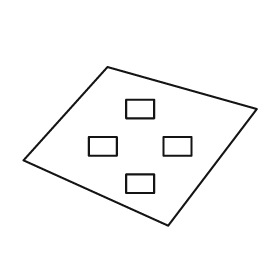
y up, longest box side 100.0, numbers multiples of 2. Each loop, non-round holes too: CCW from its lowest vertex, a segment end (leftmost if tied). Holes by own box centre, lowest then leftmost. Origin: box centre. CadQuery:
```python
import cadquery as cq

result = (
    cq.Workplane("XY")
    .moveTo(12.0, -34.0)
    .lineTo(50.0, 16.0)
    .lineTo(-14.0, 34.0)
    .lineTo(-50.0, -6.0)
    .close()
    .moveTo(-6.0, -20.0)
    .lineTo(6.0, -20.0)
    .lineTo(6.0, -12.0)
    .lineTo(-6.0, -12.0)
    .close()
    .moveTo(-22.0, -4.0)
    .lineTo(-10.0, -4.0)
    .lineTo(-10.0, 4.0)
    .lineTo(-22.0, 4.0)
    .close()
    .moveTo(10.0, -4.0)
    .lineTo(22.0, -4.0)
    .lineTo(22.0, 4.0)
    .lineTo(10.0, 4.0)
    .close()
    .moveTo(-6.0, 12.0)
    .lineTo(6.0, 12.0)
    .lineTo(6.0, 20.0)
    .lineTo(-6.0, 20.0)
    .close()
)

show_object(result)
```